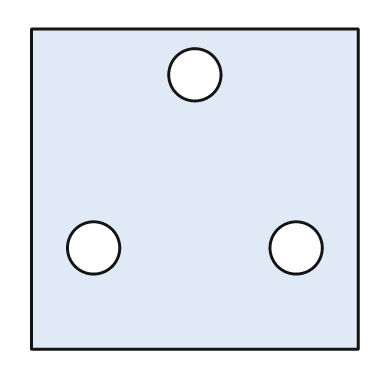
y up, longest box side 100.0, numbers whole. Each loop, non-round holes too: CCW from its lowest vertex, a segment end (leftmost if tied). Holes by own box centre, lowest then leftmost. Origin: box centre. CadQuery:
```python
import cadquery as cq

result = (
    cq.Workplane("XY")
    .moveTo(-50.0, -49.0)
    .lineTo(50.0, -49.0)
    .lineTo(50.0, 49.0)
    .lineTo(-50.0, 49.0)
    .close()
    .moveTo(-31.0, -18.0)
    .circle(8.0)
    .moveTo(31.0, -18.0)
    .circle(8.0)
    .moveTo(0.0, 35.0)
    .circle(8.0)
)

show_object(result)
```